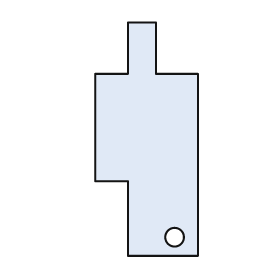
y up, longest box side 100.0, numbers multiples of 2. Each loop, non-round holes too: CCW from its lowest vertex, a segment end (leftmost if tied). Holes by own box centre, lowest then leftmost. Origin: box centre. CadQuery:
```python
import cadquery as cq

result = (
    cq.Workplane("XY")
    .moveTo(-8.0, -50.0)
    .lineTo(22.0, -50.0)
    .lineTo(22.0, 28.0)
    .lineTo(4.0, 28.0)
    .lineTo(4.0, 50.0)
    .lineTo(-8.0, 50.0)
    .lineTo(-8.0, 28.0)
    .lineTo(-22.0, 28.0)
    .lineTo(-22.0, -18.0)
    .lineTo(-8.0, -18.0)
    .close()
    .moveTo(12.0, -42.0)
    .circle(4.0)
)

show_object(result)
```